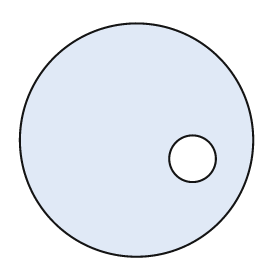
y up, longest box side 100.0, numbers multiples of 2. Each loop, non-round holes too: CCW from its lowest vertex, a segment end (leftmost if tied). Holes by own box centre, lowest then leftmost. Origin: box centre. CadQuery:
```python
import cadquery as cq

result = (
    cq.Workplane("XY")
    .moveTo(0.0, 0.0)
    .circle(50.0)
    .moveTo(24.0, -8.0)
    .circle(10.0)
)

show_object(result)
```